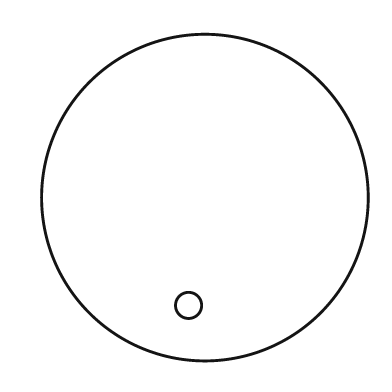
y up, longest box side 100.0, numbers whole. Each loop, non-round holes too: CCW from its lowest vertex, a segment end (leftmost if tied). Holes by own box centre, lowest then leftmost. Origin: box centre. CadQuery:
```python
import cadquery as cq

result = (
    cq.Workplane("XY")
    .moveTo(0.0, 0.0)
    .circle(50.0)
    .moveTo(-5.0, -33.0)
    .circle(4.0)
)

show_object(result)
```